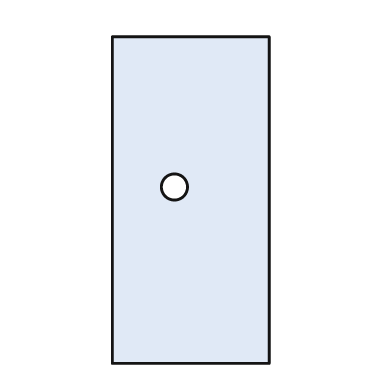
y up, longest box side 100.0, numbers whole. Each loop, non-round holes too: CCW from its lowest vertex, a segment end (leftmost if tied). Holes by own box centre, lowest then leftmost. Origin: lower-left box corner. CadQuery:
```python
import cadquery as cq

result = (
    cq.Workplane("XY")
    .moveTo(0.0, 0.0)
    .lineTo(48.0, 0.0)
    .lineTo(48.0, 100.0)
    .lineTo(0.0, 100.0)
    .close()
    .moveTo(19.0, 54.0)
    .circle(4.0)
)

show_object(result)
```